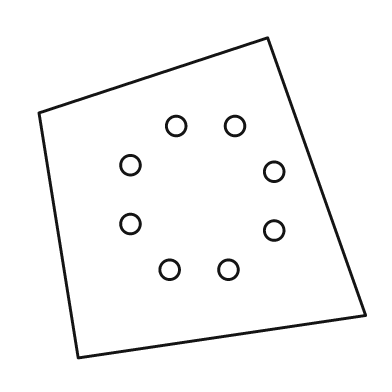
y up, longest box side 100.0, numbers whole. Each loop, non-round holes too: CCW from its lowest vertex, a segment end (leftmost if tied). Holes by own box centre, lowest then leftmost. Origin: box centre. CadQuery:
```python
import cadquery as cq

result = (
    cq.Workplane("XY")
    .moveTo(-38.0, -49.0)
    .lineTo(50.0, -36.0)
    .lineTo(20.0, 49.0)
    .lineTo(-50.0, 26.0)
    .close()
    .moveTo(-10.0, -22.0)
    .circle(3.0)
    .moveTo(8.0, -22.0)
    .circle(3.0)
    .moveTo(22.0, -10.0)
    .circle(3.0)
    .moveTo(-22.0, -8.0)
    .circle(3.0)
    .moveTo(22.0, 8.0)
    .circle(3.0)
    .moveTo(-22.0, 10.0)
    .circle(3.0)
    .moveTo(-8.0, 22.0)
    .circle(3.0)
    .moveTo(10.0, 22.0)
    .circle(3.0)
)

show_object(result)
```